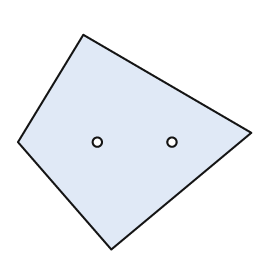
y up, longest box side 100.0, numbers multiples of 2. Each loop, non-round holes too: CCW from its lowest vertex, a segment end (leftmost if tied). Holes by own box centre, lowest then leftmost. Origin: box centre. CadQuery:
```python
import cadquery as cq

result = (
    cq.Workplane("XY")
    .moveTo(-10.0, -46.0)
    .lineTo(50.0, 4.0)
    .lineTo(-22.0, 46.0)
    .lineTo(-50.0, 0.0)
    .close()
    .moveTo(-16.0, 0.0)
    .circle(2.0)
    .moveTo(16.0, 0.0)
    .circle(2.0)
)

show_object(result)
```